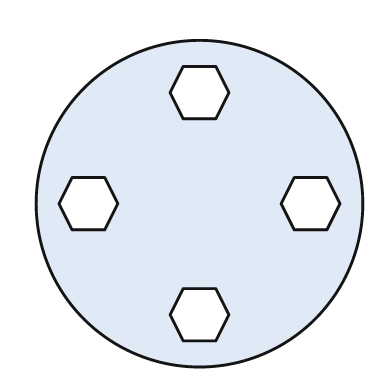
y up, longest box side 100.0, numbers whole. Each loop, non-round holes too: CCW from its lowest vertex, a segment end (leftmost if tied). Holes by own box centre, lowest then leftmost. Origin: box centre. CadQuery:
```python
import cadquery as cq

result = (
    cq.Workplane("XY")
    .moveTo(0.0, 0.0)
    .circle(50.0)
    .moveTo(-5.0, -42.0)
    .lineTo(5.0, -42.0)
    .lineTo(9.0, -34.0)
    .lineTo(5.0, -26.0)
    .lineTo(-5.0, -26.0)
    .lineTo(-9.0, -34.0)
    .close()
    .moveTo(-39.0, -8.0)
    .lineTo(-29.0, -8.0)
    .lineTo(-25.0, 0.0)
    .lineTo(-29.0, 8.0)
    .lineTo(-39.0, 8.0)
    .lineTo(-43.0, 0.0)
    .close()
    .moveTo(29.0, -8.0)
    .lineTo(39.0, -8.0)
    .lineTo(43.0, 0.0)
    .lineTo(39.0, 8.0)
    .lineTo(29.0, 8.0)
    .lineTo(25.0, 0.0)
    .close()
    .moveTo(-5.0, 26.0)
    .lineTo(5.0, 26.0)
    .lineTo(9.0, 34.0)
    .lineTo(5.0, 42.0)
    .lineTo(-5.0, 42.0)
    .lineTo(-9.0, 34.0)
    .close()
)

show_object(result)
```